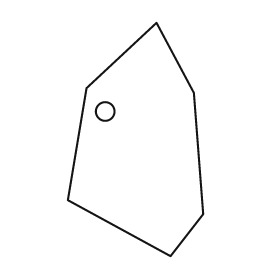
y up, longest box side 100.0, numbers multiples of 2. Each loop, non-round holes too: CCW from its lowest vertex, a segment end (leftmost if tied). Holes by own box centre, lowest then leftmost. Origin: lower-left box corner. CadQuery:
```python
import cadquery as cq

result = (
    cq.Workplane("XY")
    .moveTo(44.0, 0.0)
    .lineTo(58.0, 18.0)
    .lineTo(54.0, 70.0)
    .lineTo(38.0, 100.0)
    .lineTo(8.0, 72.0)
    .lineTo(0.0, 24.0)
    .close()
    .moveTo(16.0, 62.0)
    .circle(4.0)
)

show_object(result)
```